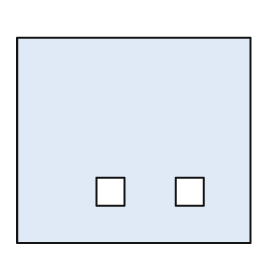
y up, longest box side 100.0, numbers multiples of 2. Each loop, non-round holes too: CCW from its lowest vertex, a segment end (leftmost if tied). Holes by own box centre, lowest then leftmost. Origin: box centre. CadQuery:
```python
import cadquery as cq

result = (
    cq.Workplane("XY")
    .moveTo(-50.0, -44.0)
    .lineTo(50.0, -44.0)
    .lineTo(50.0, 44.0)
    .lineTo(-50.0, 44.0)
    .close()
    .moveTo(-16.0, -28.0)
    .lineTo(-4.0, -28.0)
    .lineTo(-4.0, -16.0)
    .lineTo(-16.0, -16.0)
    .close()
    .moveTo(18.0, -28.0)
    .lineTo(30.0, -28.0)
    .lineTo(30.0, -16.0)
    .lineTo(18.0, -16.0)
    .close()
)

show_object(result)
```